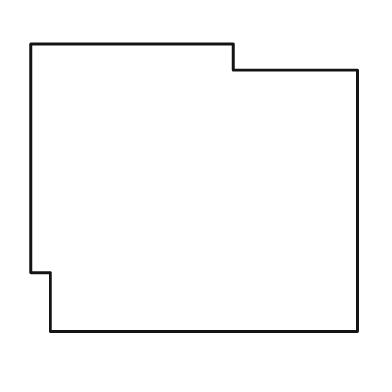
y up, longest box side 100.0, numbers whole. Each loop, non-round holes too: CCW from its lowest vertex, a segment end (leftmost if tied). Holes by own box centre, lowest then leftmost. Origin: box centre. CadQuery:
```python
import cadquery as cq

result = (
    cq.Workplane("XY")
    .moveTo(-44.0, -44.0)
    .lineTo(50.0, -44.0)
    .lineTo(50.0, 36.0)
    .lineTo(12.0, 36.0)
    .lineTo(12.0, 44.0)
    .lineTo(-50.0, 44.0)
    .lineTo(-50.0, -26.0)
    .lineTo(-44.0, -26.0)
    .close()
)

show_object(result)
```